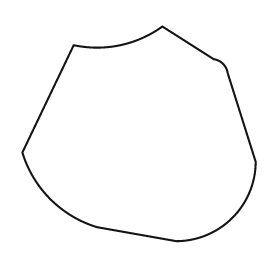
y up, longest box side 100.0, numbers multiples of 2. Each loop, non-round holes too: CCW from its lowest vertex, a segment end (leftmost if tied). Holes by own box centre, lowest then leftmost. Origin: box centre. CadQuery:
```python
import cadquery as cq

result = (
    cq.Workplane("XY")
    .moveTo(16.0, -46.0)
    .threePointArc((40.0, -36.0), (50.0, -12.0))
    .lineTo(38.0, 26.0)
    .threePointArc((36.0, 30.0), (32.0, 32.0))
    .lineTo(10.0, 46.0)
    .threePointArc((-8.0, 38.0), (-28.0, 38.0))
    .lineTo(-50.0, -8.0)
    .threePointArc((-38.0, -28.0), (-18.0, -40.0))
    .close()
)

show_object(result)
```